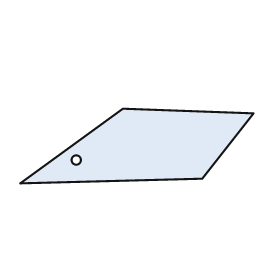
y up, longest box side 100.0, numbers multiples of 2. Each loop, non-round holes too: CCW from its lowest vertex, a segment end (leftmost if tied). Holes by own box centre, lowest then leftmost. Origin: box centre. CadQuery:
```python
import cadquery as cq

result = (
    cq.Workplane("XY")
    .moveTo(-50.0, -16.0)
    .lineTo(28.0, -14.0)
    .lineTo(50.0, 14.0)
    .lineTo(-6.0, 16.0)
    .close()
    .moveTo(-26.0, -6.0)
    .circle(2.0)
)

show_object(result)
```